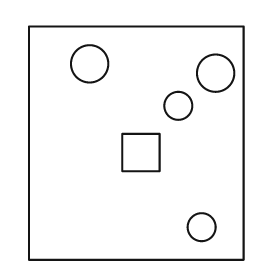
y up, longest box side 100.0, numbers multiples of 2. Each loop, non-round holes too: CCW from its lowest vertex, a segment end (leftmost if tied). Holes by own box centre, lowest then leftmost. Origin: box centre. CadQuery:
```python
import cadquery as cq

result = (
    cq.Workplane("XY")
    .moveTo(-46.0, -50.0)
    .lineTo(46.0, -50.0)
    .lineTo(46.0, 50.0)
    .lineTo(-46.0, 50.0)
    .close()
    .moveTo(28.0, -36.0)
    .circle(6.0)
    .moveTo(-6.0, -12.0)
    .lineTo(10.0, -12.0)
    .lineTo(10.0, 4.0)
    .lineTo(-6.0, 4.0)
    .close()
    .moveTo(18.0, 16.0)
    .circle(6.0)
    .moveTo(34.0, 30.0)
    .circle(8.0)
    .moveTo(-20.0, 34.0)
    .circle(8.0)
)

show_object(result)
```